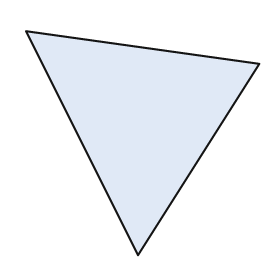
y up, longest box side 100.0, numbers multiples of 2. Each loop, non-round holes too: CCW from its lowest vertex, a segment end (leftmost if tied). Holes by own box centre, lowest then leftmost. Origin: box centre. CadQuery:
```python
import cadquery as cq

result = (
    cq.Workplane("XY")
    .moveTo(-2.0, -48.0)
    .lineTo(50.0, 34.0)
    .lineTo(-50.0, 48.0)
    .close()
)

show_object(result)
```